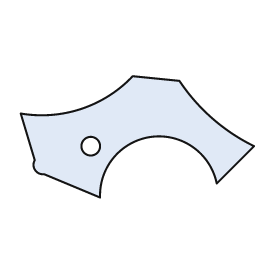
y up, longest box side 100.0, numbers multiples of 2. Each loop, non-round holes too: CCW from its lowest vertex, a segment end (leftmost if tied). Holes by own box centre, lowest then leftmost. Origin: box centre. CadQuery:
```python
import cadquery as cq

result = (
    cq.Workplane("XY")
    .moveTo(-16.0, -26.0)
    .threePointArc((6.0, 0.0), (34.0, -20.0))
    .lineTo(50.0, -4.0)
    .threePointArc((32.0, 8.0), (18.0, 24.0))
    .lineTo(-2.0, 26.0)
    .threePointArc((-24.0, 12.0), (-50.0, 10.0))
    .lineTo(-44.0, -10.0)
    .threePointArc((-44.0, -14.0), (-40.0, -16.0))
    .close()
    .moveTo(-20.0, -4.0)
    .circle(4.0)
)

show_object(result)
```